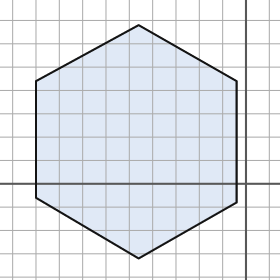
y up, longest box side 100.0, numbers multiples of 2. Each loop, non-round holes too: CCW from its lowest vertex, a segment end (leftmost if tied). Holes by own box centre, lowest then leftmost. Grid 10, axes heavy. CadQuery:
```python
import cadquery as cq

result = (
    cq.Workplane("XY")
    .moveTo(-46.0, -32.0)
    .lineTo(-4.0, -8.0)
    .lineTo(-4.0, 44.0)
    .lineTo(-46.0, 68.0)
    .lineTo(-90.0, 44.0)
    .lineTo(-90.0, -6.0)
    .close()
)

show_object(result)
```